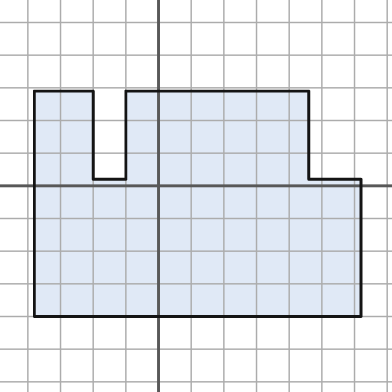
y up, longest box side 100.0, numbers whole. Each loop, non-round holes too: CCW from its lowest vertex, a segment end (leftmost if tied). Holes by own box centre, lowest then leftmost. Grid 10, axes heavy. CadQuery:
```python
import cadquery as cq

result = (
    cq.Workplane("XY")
    .moveTo(-38.0, -40.0)
    .lineTo(62.0, -40.0)
    .lineTo(62.0, 2.0)
    .lineTo(46.0, 2.0)
    .lineTo(46.0, 29.0)
    .lineTo(-10.0, 29.0)
    .lineTo(-10.0, 2.0)
    .lineTo(-20.0, 2.0)
    .lineTo(-20.0, 29.0)
    .lineTo(-38.0, 29.0)
    .close()
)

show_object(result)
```